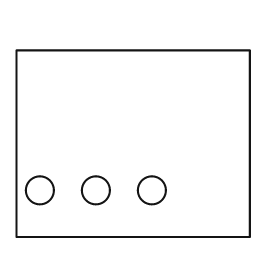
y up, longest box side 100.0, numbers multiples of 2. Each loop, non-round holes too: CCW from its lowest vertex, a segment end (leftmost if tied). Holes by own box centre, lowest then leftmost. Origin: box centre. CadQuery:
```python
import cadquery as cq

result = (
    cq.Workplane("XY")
    .moveTo(-50.0, -40.0)
    .lineTo(50.0, -40.0)
    .lineTo(50.0, 40.0)
    .lineTo(-50.0, 40.0)
    .close()
    .moveTo(-40.0, -20.0)
    .circle(6.0)
    .moveTo(-16.0, -20.0)
    .circle(6.0)
    .moveTo(8.0, -20.0)
    .circle(6.0)
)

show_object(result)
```